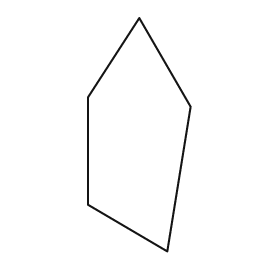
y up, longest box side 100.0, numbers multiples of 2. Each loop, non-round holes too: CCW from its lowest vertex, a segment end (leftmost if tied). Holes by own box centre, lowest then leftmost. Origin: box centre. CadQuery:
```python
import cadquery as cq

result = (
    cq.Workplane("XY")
    .moveTo(12.0, -50.0)
    .lineTo(22.0, 12.0)
    .lineTo(0.0, 50.0)
    .lineTo(-22.0, 16.0)
    .lineTo(-22.0, -30.0)
    .close()
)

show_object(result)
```